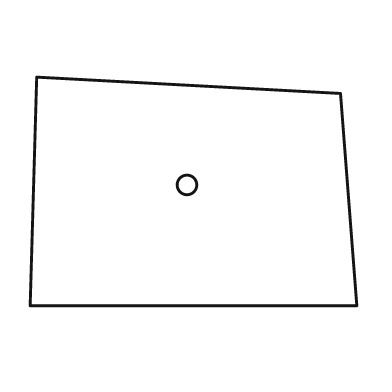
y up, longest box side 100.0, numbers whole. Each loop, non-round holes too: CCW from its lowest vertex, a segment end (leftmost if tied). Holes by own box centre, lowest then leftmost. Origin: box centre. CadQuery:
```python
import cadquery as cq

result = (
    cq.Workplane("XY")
    .moveTo(-50.0, -35.0)
    .lineTo(50.0, -35.0)
    .lineTo(45.0, 30.0)
    .lineTo(-48.0, 35.0)
    .close()
    .moveTo(-2.0, 2.0)
    .circle(3.0)
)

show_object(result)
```